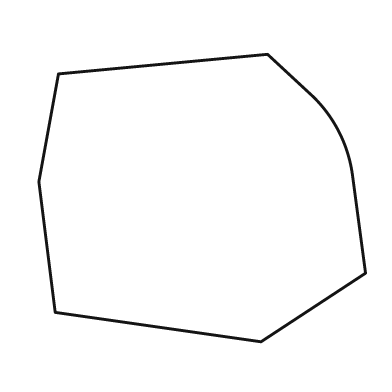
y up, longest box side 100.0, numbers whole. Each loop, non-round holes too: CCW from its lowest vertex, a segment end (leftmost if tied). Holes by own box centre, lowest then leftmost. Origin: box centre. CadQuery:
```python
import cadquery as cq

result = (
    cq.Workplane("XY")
    .moveTo(18.0, -44.0)
    .lineTo(50.0, -23.0)
    .lineTo(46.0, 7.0)
    .threePointArc((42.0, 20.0), (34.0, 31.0))
    .lineTo(20.0, 44.0)
    .lineTo(-44.0, 38.0)
    .lineTo(-50.0, 5.0)
    .lineTo(-45.0, -35.0)
    .close()
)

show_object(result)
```